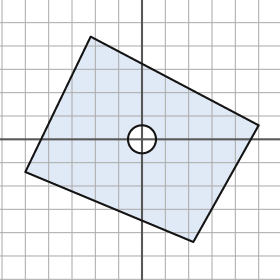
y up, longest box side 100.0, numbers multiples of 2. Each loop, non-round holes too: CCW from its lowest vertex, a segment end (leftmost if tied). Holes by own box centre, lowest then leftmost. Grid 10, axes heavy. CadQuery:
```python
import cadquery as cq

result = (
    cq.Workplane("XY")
    .moveTo(22.0, -44.0)
    .lineTo(50.0, 6.0)
    .lineTo(-22.0, 44.0)
    .lineTo(-50.0, -14.0)
    .close()
    .moveTo(0.0, 0.0)
    .circle(6.0)
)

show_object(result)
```